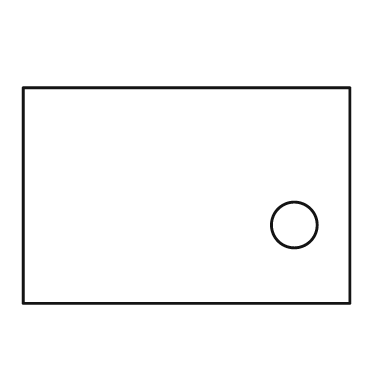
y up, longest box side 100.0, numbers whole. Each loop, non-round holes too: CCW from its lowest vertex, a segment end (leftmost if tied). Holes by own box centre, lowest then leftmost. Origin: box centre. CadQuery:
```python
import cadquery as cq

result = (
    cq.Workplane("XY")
    .moveTo(-50.0, -33.0)
    .lineTo(50.0, -33.0)
    .lineTo(50.0, 33.0)
    .lineTo(-50.0, 33.0)
    .close()
    .moveTo(33.0, -9.0)
    .circle(7.0)
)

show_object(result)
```